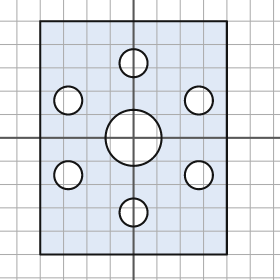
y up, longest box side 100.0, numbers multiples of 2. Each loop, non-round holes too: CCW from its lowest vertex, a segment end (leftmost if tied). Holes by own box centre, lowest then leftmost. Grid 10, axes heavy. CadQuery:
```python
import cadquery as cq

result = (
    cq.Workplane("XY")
    .moveTo(-40.0, -50.0)
    .lineTo(40.0, -50.0)
    .lineTo(40.0, 50.0)
    .lineTo(-40.0, 50.0)
    .close()
    .moveTo(0.0, -32.0)
    .circle(6.0)
    .moveTo(-28.0, -16.0)
    .circle(6.0)
    .moveTo(28.0, -16.0)
    .circle(6.0)
    .moveTo(0.0, 0.0)
    .circle(12.0)
    .moveTo(-28.0, 16.0)
    .circle(6.0)
    .moveTo(28.0, 16.0)
    .circle(6.0)
    .moveTo(0.0, 32.0)
    .circle(6.0)
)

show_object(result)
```